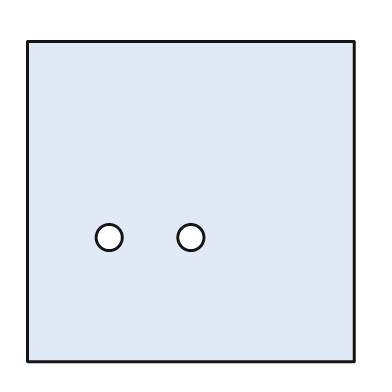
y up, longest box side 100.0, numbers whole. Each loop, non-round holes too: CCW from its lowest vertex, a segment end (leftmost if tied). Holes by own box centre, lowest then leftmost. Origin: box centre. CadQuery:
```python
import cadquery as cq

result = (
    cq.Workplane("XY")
    .moveTo(-50.0, -49.0)
    .lineTo(50.0, -49.0)
    .lineTo(50.0, 49.0)
    .lineTo(-50.0, 49.0)
    .close()
    .moveTo(-25.0, -11.0)
    .circle(4.0)
    .moveTo(0.0, -11.0)
    .circle(4.0)
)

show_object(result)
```